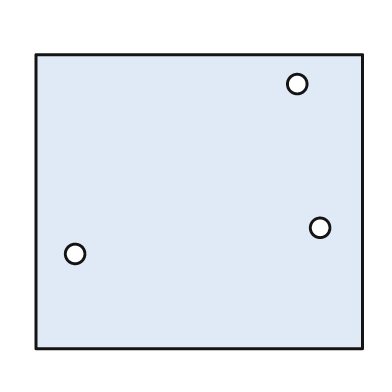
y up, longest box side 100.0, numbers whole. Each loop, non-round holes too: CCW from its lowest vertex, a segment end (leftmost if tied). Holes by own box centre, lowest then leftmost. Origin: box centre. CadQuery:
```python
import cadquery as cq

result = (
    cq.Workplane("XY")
    .moveTo(-50.0, -45.0)
    .lineTo(50.0, -45.0)
    .lineTo(50.0, 45.0)
    .lineTo(-50.0, 45.0)
    .close()
    .moveTo(-38.0, -16.0)
    .circle(3.0)
    .moveTo(37.0, -8.0)
    .circle(3.0)
    .moveTo(30.0, 36.0)
    .circle(3.0)
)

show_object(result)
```